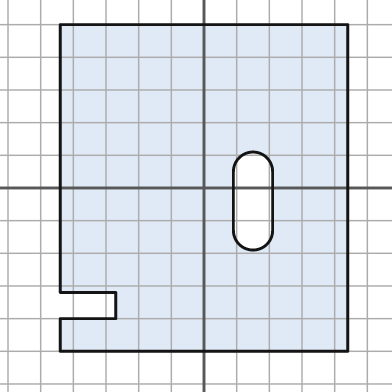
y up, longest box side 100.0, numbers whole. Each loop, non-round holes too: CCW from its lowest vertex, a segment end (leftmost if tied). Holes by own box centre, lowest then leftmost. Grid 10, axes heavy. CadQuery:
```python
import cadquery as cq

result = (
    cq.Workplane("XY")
    .moveTo(-44.0, -50.0)
    .lineTo(44.0, -50.0)
    .lineTo(44.0, 50.0)
    .lineTo(-44.0, 50.0)
    .lineTo(-44.0, -32.0)
    .lineTo(-27.0, -32.0)
    .lineTo(-27.0, -40.0)
    .lineTo(-44.0, -40.0)
    .close()
    .moveTo(9.0, -13.0)
    .threePointArc((15.0, -19.0), (21.0, -13.0))
    .lineTo(21.0, 5.0)
    .threePointArc((15.0, 11.0), (9.0, 5.0))
    .close()
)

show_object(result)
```